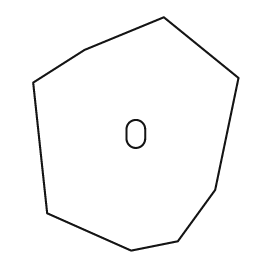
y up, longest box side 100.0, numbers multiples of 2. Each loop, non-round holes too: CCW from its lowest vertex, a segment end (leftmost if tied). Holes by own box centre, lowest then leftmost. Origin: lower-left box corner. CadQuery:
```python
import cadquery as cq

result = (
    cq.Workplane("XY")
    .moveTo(42.0, 0.0)
    .lineTo(62.0, 4.0)
    .lineTo(78.0, 26.0)
    .lineTo(88.0, 74.0)
    .lineTo(56.0, 100.0)
    .lineTo(22.0, 86.0)
    .lineTo(0.0, 72.0)
    .lineTo(6.0, 16.0)
    .close()
    .moveTo(40.0, 48.0)
    .threePointArc((44.0, 44.0), (48.0, 48.0))
    .lineTo(48.0, 52.0)
    .threePointArc((44.0, 56.0), (40.0, 52.0))
    .close()
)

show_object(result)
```